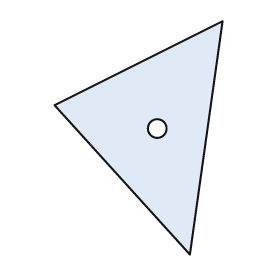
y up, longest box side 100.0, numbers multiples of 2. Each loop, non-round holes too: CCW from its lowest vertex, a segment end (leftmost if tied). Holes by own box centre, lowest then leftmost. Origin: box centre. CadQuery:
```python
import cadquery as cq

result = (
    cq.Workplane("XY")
    .moveTo(22.0, -50.0)
    .lineTo(36.0, 50.0)
    .lineTo(-36.0, 14.0)
    .close()
    .moveTo(8.0, 4.0)
    .circle(4.0)
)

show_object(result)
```